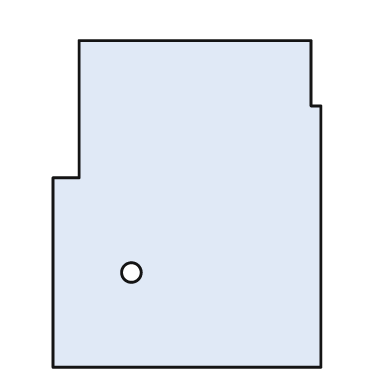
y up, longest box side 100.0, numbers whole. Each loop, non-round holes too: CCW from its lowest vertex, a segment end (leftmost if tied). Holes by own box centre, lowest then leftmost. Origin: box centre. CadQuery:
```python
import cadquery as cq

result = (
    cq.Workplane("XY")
    .moveTo(-41.0, -50.0)
    .lineTo(41.0, -50.0)
    .lineTo(41.0, 30.0)
    .lineTo(38.0, 30.0)
    .lineTo(38.0, 50.0)
    .lineTo(-33.0, 50.0)
    .lineTo(-33.0, 8.0)
    .lineTo(-41.0, 8.0)
    .close()
    .moveTo(-17.0, -21.0)
    .circle(3.0)
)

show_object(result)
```